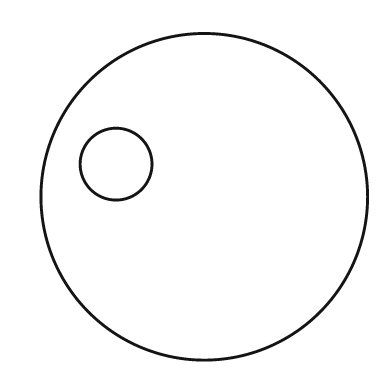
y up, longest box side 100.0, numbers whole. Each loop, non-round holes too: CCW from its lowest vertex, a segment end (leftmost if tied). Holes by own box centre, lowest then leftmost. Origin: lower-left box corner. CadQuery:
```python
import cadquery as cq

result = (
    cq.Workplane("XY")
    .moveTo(50.0, 50.0)
    .circle(50.0)
    .moveTo(23.0, 60.0)
    .circle(11.0)
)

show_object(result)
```